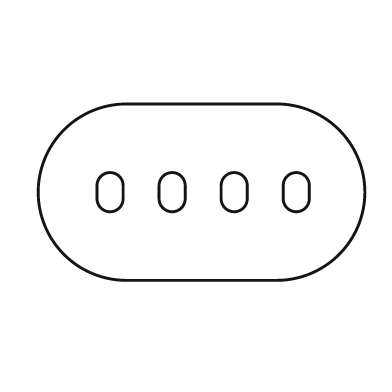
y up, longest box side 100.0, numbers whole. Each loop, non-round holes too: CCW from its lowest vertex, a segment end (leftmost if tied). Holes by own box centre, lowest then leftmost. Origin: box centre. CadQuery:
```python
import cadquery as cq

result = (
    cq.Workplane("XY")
    .moveTo(-23.0, -27.0)
    .lineTo(23.0, -27.0)
    .threePointArc((50.0, 0.0), (23.0, 27.0))
    .lineTo(-23.0, 27.0)
    .threePointArc((-50.0, 0.0), (-23.0, -27.0))
    .close()
    .moveTo(-32.0, -2.0)
    .threePointArc((-28.0, -6.0), (-24.0, -2.0))
    .lineTo(-24.0, 2.0)
    .threePointArc((-28.0, 6.0), (-32.0, 2.0))
    .close()
    .moveTo(-13.0, -2.0)
    .threePointArc((-9.0, -6.0), (-5.0, -2.0))
    .lineTo(-5.0, 2.0)
    .threePointArc((-9.0, 6.0), (-13.0, 2.0))
    .close()
    .moveTo(6.0, -2.0)
    .threePointArc((10.0, -6.0), (14.0, -2.0))
    .lineTo(14.0, 2.0)
    .threePointArc((10.0, 6.0), (6.0, 2.0))
    .close()
    .moveTo(25.0, -2.0)
    .threePointArc((29.0, -6.0), (33.0, -2.0))
    .lineTo(33.0, 2.0)
    .threePointArc((29.0, 6.0), (25.0, 2.0))
    .close()
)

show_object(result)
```